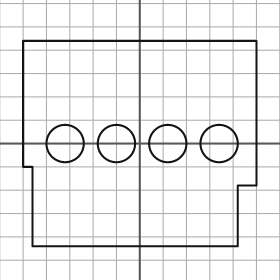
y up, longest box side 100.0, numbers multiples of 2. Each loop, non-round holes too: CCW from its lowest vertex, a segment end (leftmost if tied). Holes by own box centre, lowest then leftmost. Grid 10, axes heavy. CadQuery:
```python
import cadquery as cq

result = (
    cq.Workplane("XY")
    .moveTo(-46.0, -44.0)
    .lineTo(42.0, -44.0)
    .lineTo(42.0, -18.0)
    .lineTo(50.0, -18.0)
    .lineTo(50.0, 44.0)
    .lineTo(-50.0, 44.0)
    .lineTo(-50.0, -10.0)
    .lineTo(-46.0, -10.0)
    .close()
    .moveTo(-32.0, 0.0)
    .circle(8.0)
    .moveTo(-10.0, 0.0)
    .circle(8.0)
    .moveTo(12.0, 0.0)
    .circle(8.0)
    .moveTo(34.0, 0.0)
    .circle(8.0)
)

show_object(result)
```